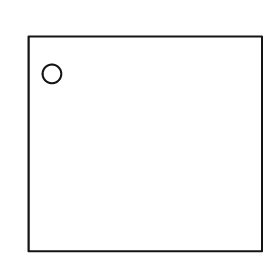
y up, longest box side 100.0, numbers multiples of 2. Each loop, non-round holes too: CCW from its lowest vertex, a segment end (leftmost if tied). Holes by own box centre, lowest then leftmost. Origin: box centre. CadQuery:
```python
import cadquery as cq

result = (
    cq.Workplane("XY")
    .moveTo(-50.0, -46.0)
    .lineTo(50.0, -46.0)
    .lineTo(50.0, 46.0)
    .lineTo(-50.0, 46.0)
    .close()
    .moveTo(-40.0, 30.0)
    .circle(4.0)
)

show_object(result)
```